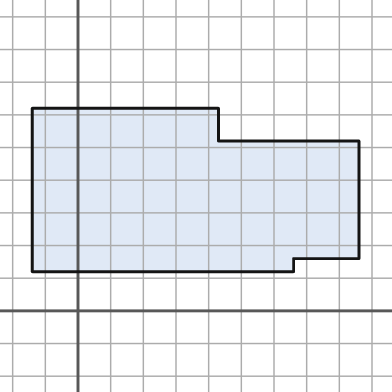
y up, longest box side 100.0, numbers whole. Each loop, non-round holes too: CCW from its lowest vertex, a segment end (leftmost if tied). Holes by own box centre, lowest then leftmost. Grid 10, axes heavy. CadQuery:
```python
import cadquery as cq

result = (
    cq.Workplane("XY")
    .moveTo(-14.0, 12.0)
    .lineTo(66.0, 12.0)
    .lineTo(66.0, 16.0)
    .lineTo(86.0, 16.0)
    .lineTo(86.0, 52.0)
    .lineTo(43.0, 52.0)
    .lineTo(43.0, 62.0)
    .lineTo(-14.0, 62.0)
    .close()
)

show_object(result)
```